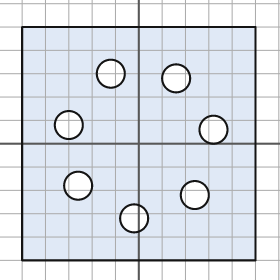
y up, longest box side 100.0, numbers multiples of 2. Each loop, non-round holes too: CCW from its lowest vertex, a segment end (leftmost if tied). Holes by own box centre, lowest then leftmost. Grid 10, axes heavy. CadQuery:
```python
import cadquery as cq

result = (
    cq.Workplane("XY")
    .moveTo(-50.0, -50.0)
    .lineTo(50.0, -50.0)
    .lineTo(50.0, 50.0)
    .lineTo(-50.0, 50.0)
    .close()
    .moveTo(-2.0, -32.0)
    .circle(6.0)
    .moveTo(24.0, -22.0)
    .circle(6.0)
    .moveTo(-26.0, -18.0)
    .circle(6.0)
    .moveTo(32.0, 6.0)
    .circle(6.0)
    .moveTo(-30.0, 8.0)
    .circle(6.0)
    .moveTo(16.0, 28.0)
    .circle(6.0)
    .moveTo(-12.0, 30.0)
    .circle(6.0)
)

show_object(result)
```